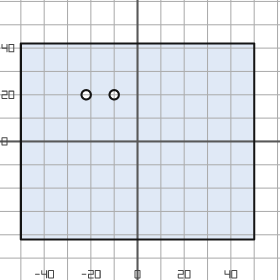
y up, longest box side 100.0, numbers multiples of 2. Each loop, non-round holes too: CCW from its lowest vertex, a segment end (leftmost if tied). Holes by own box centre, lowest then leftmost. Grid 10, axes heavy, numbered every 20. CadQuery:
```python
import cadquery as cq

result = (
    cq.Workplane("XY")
    .moveTo(-50.0, -42.0)
    .lineTo(50.0, -42.0)
    .lineTo(50.0, 42.0)
    .lineTo(-50.0, 42.0)
    .close()
    .moveTo(-22.0, 20.0)
    .circle(2.0)
    .moveTo(-10.0, 20.0)
    .circle(2.0)
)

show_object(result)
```